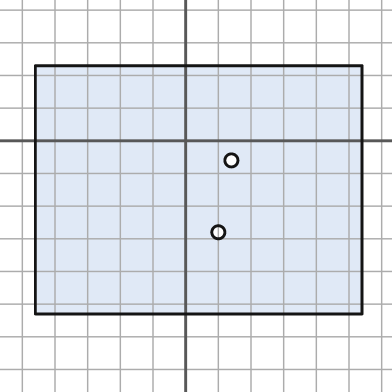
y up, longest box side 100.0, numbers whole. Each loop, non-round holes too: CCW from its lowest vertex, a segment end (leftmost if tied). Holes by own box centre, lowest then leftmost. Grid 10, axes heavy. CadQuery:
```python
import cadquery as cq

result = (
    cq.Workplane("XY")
    .moveTo(-46.0, -53.0)
    .lineTo(54.0, -53.0)
    .lineTo(54.0, 23.0)
    .lineTo(-46.0, 23.0)
    .close()
    .moveTo(10.0, -28.0)
    .circle(2.0)
    .moveTo(14.0, -6.0)
    .circle(2.0)
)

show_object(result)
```